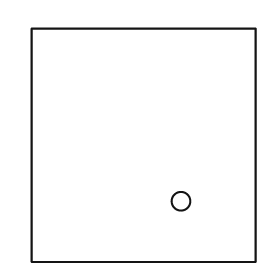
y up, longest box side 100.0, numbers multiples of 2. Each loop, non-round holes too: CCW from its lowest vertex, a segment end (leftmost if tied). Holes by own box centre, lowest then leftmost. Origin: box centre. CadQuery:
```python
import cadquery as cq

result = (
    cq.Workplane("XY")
    .moveTo(-48.0, -50.0)
    .lineTo(48.0, -50.0)
    .lineTo(48.0, 50.0)
    .lineTo(-48.0, 50.0)
    .close()
    .moveTo(16.0, -24.0)
    .circle(4.0)
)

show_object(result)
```